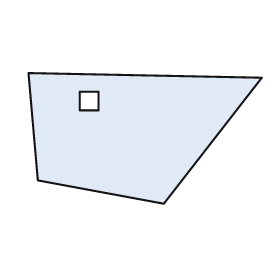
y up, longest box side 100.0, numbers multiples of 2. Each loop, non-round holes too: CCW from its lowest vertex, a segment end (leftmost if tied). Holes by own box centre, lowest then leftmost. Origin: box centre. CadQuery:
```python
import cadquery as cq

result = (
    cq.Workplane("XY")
    .moveTo(8.0, -28.0)
    .lineTo(50.0, 26.0)
    .lineTo(-50.0, 28.0)
    .lineTo(-46.0, -18.0)
    .close()
    .moveTo(-28.0, 12.0)
    .lineTo(-20.0, 12.0)
    .lineTo(-20.0, 20.0)
    .lineTo(-28.0, 20.0)
    .close()
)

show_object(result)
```